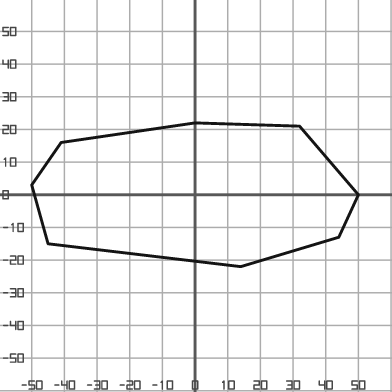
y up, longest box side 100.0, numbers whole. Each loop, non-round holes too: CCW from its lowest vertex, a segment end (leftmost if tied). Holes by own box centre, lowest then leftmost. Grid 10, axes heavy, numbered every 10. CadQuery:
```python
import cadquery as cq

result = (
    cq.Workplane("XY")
    .moveTo(14.0, -22.0)
    .lineTo(44.0, -13.0)
    .lineTo(50.0, 0.0)
    .lineTo(32.0, 21.0)
    .lineTo(0.0, 22.0)
    .lineTo(-41.0, 16.0)
    .lineTo(-50.0, 3.0)
    .lineTo(-45.0, -15.0)
    .close()
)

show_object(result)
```